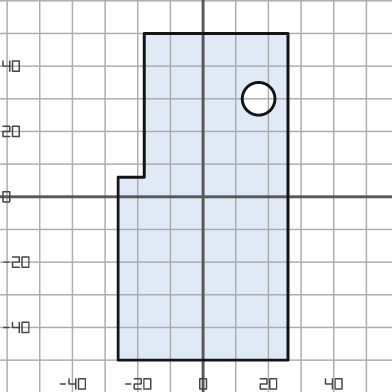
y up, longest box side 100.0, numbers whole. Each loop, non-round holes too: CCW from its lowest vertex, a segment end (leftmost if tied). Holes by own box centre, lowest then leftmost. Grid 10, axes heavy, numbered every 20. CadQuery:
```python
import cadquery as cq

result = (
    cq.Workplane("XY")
    .moveTo(-26.0, -50.0)
    .lineTo(26.0, -50.0)
    .lineTo(26.0, 50.0)
    .lineTo(-18.0, 50.0)
    .lineTo(-18.0, 6.0)
    .lineTo(-26.0, 6.0)
    .close()
    .moveTo(17.0, 30.0)
    .circle(5.0)
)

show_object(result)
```